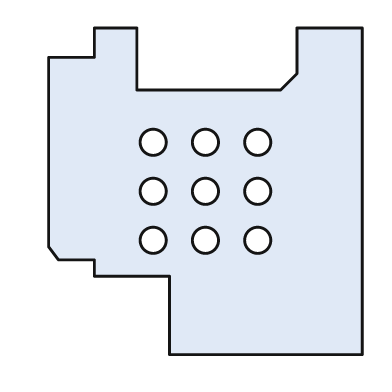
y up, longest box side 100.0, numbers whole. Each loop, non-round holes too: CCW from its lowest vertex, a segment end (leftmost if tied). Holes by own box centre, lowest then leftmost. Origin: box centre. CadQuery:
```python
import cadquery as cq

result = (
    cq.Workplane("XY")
    .moveTo(-11.0, -50.0)
    .lineTo(48.0, -50.0)
    .lineTo(48.0, 50.0)
    .lineTo(28.0, 50.0)
    .lineTo(28.0, 36.0)
    .lineTo(23.0, 31.0)
    .lineTo(-21.0, 31.0)
    .lineTo(-21.0, 50.0)
    .lineTo(-34.0, 50.0)
    .lineTo(-34.0, 41.0)
    .lineTo(-48.0, 41.0)
    .lineTo(-48.0, -17.0)
    .lineTo(-45.0, -21.0)
    .lineTo(-34.0, -21.0)
    .lineTo(-34.0, -26.0)
    .lineTo(-11.0, -26.0)
    .close()
    .moveTo(-16.0, -15.0)
    .circle(4.0)
    .moveTo(0.0, -15.0)
    .circle(4.0)
    .moveTo(16.0, -15.0)
    .circle(4.0)
    .moveTo(-16.0, 0.0)
    .circle(4.0)
    .moveTo(0.0, 0.0)
    .circle(4.0)
    .moveTo(16.0, 0.0)
    .circle(4.0)
    .moveTo(-16.0, 15.0)
    .circle(4.0)
    .moveTo(0.0, 15.0)
    .circle(4.0)
    .moveTo(16.0, 15.0)
    .circle(4.0)
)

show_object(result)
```